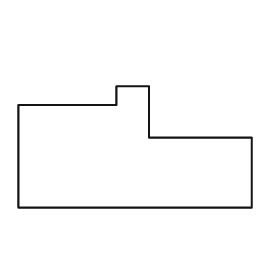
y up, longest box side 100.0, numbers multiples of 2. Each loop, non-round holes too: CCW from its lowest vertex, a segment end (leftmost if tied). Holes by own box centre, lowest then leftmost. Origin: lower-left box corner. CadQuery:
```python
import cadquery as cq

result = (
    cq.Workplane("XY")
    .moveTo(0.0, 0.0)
    .lineTo(100.0, 0.0)
    .lineTo(100.0, 30.0)
    .lineTo(56.0, 30.0)
    .lineTo(56.0, 52.0)
    .lineTo(42.0, 52.0)
    .lineTo(42.0, 44.0)
    .lineTo(0.0, 44.0)
    .close()
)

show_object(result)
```